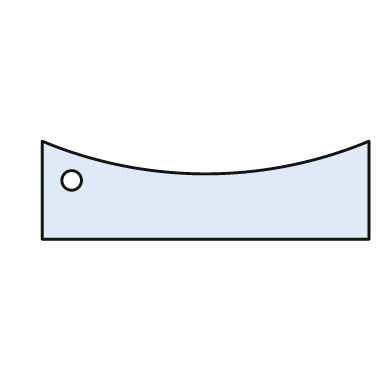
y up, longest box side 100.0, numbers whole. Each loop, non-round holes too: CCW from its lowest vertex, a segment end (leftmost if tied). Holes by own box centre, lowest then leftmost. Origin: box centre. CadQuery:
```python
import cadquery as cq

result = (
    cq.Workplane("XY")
    .moveTo(-50.0, -15.0)
    .lineTo(50.0, -15.0)
    .lineTo(50.0, 15.0)
    .threePointArc((0.0, 5.0), (-50.0, 15.0))
    .close()
    .moveTo(-41.0, 3.0)
    .circle(3.0)
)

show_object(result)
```